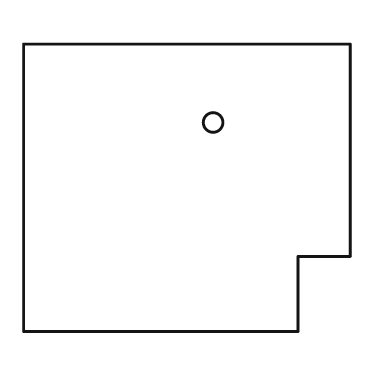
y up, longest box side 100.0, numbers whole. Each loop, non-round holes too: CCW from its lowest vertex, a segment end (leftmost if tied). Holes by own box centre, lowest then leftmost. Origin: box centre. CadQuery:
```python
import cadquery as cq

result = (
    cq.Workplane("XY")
    .moveTo(-50.0, -44.0)
    .lineTo(34.0, -44.0)
    .lineTo(34.0, -21.0)
    .lineTo(50.0, -21.0)
    .lineTo(50.0, 44.0)
    .lineTo(-50.0, 44.0)
    .close()
    .moveTo(8.0, 20.0)
    .circle(3.0)
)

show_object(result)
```